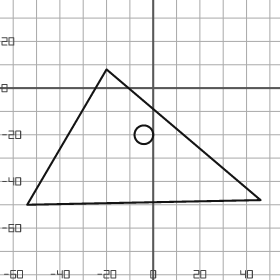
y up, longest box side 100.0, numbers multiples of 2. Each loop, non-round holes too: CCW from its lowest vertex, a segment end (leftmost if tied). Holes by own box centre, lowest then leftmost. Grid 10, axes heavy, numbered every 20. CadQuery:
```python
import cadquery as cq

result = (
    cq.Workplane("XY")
    .moveTo(-54.0, -50.0)
    .lineTo(46.0, -48.0)
    .lineTo(-20.0, 8.0)
    .close()
    .moveTo(-4.0, -20.0)
    .circle(4.0)
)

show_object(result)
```